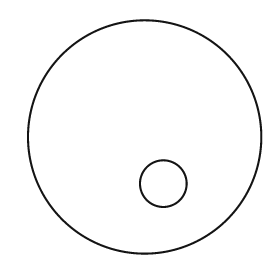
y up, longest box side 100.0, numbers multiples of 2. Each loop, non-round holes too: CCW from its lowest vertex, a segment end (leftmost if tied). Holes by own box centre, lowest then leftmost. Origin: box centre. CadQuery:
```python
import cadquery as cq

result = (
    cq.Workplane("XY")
    .moveTo(0.0, 0.0)
    .circle(50.0)
    .moveTo(8.0, -20.0)
    .circle(10.0)
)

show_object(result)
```